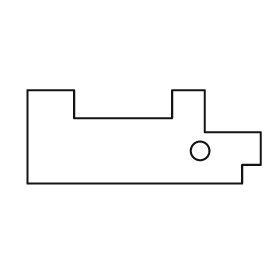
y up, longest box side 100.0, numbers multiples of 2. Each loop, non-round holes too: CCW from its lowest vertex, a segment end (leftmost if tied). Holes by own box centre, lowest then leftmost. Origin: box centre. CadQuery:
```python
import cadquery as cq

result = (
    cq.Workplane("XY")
    .moveTo(-50.0, -20.0)
    .lineTo(42.0, -20.0)
    .lineTo(42.0, -12.0)
    .lineTo(50.0, -12.0)
    .lineTo(50.0, 2.0)
    .lineTo(26.0, 2.0)
    .lineTo(26.0, 20.0)
    .lineTo(12.0, 20.0)
    .lineTo(12.0, 8.0)
    .lineTo(-30.0, 8.0)
    .lineTo(-30.0, 20.0)
    .lineTo(-50.0, 20.0)
    .close()
    .moveTo(24.0, -6.0)
    .circle(4.0)
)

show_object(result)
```